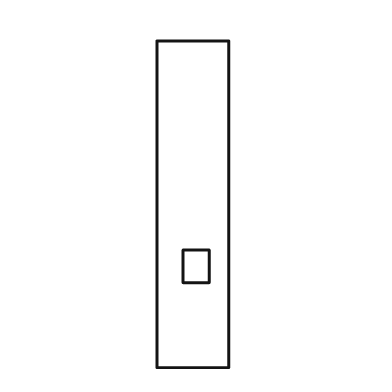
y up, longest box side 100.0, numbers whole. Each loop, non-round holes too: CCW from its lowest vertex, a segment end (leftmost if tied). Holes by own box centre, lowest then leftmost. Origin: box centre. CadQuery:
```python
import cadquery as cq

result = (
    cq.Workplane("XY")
    .moveTo(-11.0, -50.0)
    .lineTo(11.0, -50.0)
    .lineTo(11.0, 50.0)
    .lineTo(-11.0, 50.0)
    .close()
    .moveTo(-3.0, -24.0)
    .lineTo(5.0, -24.0)
    .lineTo(5.0, -14.0)
    .lineTo(-3.0, -14.0)
    .close()
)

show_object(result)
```